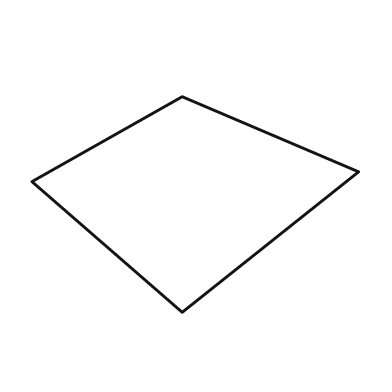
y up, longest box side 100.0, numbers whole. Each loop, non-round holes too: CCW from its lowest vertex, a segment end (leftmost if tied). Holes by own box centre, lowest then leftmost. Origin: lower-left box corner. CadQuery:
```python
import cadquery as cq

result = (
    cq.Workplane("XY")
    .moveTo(46.0, 0.0)
    .lineTo(100.0, 43.0)
    .lineTo(46.0, 66.0)
    .lineTo(0.0, 40.0)
    .close()
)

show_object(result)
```